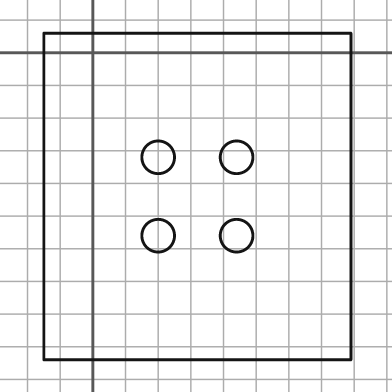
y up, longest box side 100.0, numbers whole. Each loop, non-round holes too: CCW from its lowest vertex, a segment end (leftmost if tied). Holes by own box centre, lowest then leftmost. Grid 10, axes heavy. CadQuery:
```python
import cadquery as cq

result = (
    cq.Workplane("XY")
    .moveTo(-15.0, -94.0)
    .lineTo(79.0, -94.0)
    .lineTo(79.0, 6.0)
    .lineTo(-15.0, 6.0)
    .close()
    .moveTo(20.0, -56.0)
    .circle(5.0)
    .moveTo(44.0, -56.0)
    .circle(5.0)
    .moveTo(20.0, -32.0)
    .circle(5.0)
    .moveTo(44.0, -32.0)
    .circle(5.0)
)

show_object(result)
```